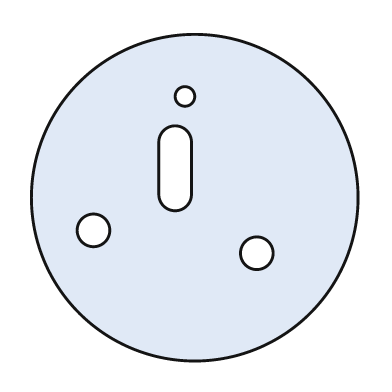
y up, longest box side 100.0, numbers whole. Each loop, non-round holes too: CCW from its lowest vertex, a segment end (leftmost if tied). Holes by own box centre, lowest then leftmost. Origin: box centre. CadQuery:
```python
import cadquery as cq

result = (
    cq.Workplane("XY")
    .moveTo(0.0, 0.0)
    .circle(50.0)
    .moveTo(19.0, -17.0)
    .circle(5.0)
    .moveTo(-31.0, -10.0)
    .circle(5.0)
    .moveTo(-11.0, 1.0)
    .threePointArc((-6.0, -4.0), (-1.0, 1.0))
    .lineTo(-1.0, 17.0)
    .threePointArc((-6.0, 22.0), (-11.0, 17.0))
    .close()
    .moveTo(-3.0, 31.0)
    .circle(3.0)
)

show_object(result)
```